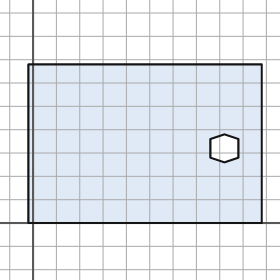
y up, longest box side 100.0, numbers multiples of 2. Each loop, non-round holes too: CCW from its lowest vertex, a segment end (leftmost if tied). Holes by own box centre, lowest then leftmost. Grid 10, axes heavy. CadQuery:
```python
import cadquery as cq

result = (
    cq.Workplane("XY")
    .moveTo(-2.0, 0.0)
    .lineTo(98.0, 0.0)
    .lineTo(98.0, 68.0)
    .lineTo(-2.0, 68.0)
    .close()
    .moveTo(82.0, 26.0)
    .lineTo(88.0, 28.0)
    .lineTo(88.0, 36.0)
    .lineTo(82.0, 38.0)
    .lineTo(76.0, 36.0)
    .lineTo(76.0, 28.0)
    .close()
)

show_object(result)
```